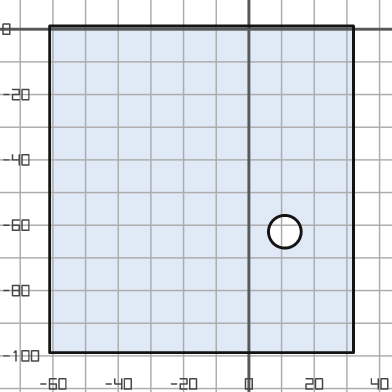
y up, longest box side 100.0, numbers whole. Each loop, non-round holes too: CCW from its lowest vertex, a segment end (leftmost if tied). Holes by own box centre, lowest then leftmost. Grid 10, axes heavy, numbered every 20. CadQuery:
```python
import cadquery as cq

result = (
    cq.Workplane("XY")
    .moveTo(-61.0, -99.0)
    .lineTo(32.0, -99.0)
    .lineTo(32.0, 1.0)
    .lineTo(-61.0, 1.0)
    .close()
    .moveTo(11.0, -62.0)
    .circle(5.0)
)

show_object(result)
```